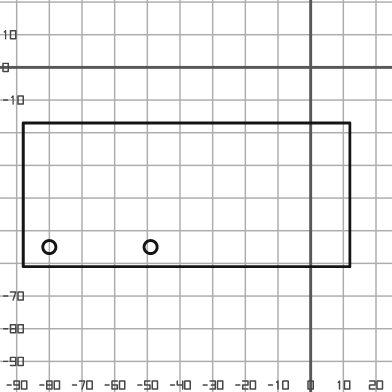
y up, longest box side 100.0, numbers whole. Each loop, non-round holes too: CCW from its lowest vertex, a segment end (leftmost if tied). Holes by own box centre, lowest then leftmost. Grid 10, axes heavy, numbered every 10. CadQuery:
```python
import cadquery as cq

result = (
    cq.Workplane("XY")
    .moveTo(-88.0, -61.0)
    .lineTo(12.0, -61.0)
    .lineTo(12.0, -17.0)
    .lineTo(-88.0, -17.0)
    .close()
    .moveTo(-80.0, -55.0)
    .circle(2.0)
    .moveTo(-49.0, -55.0)
    .circle(2.0)
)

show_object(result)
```